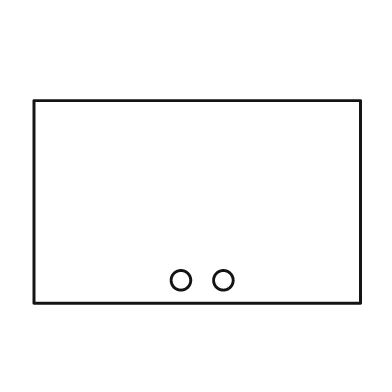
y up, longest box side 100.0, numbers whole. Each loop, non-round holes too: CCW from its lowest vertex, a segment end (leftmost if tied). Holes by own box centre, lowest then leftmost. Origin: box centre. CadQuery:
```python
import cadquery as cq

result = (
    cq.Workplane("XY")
    .moveTo(-50.0, -31.0)
    .lineTo(50.0, -31.0)
    .lineTo(50.0, 31.0)
    .lineTo(-50.0, 31.0)
    .close()
    .moveTo(-5.0, -24.0)
    .circle(3.0)
    .moveTo(8.0, -24.0)
    .circle(3.0)
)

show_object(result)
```